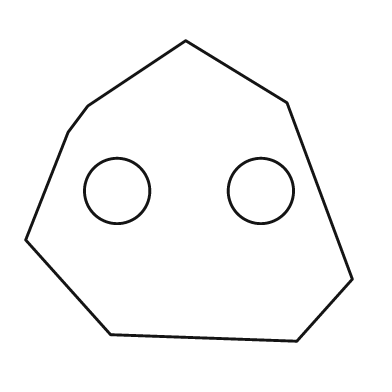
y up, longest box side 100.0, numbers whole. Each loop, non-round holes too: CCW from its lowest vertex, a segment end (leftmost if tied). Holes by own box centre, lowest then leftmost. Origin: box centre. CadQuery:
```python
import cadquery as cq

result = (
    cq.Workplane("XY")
    .moveTo(33.0, -46.0)
    .lineTo(50.0, -27.0)
    .lineTo(30.0, 27.0)
    .lineTo(-1.0, 46.0)
    .lineTo(-31.0, 26.0)
    .lineTo(-37.0, 18.0)
    .lineTo(-50.0, -15.0)
    .lineTo(-24.0, -44.0)
    .close()
    .moveTo(-22.0, 0.0)
    .circle(10.0)
    .moveTo(22.0, 0.0)
    .circle(10.0)
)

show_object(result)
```